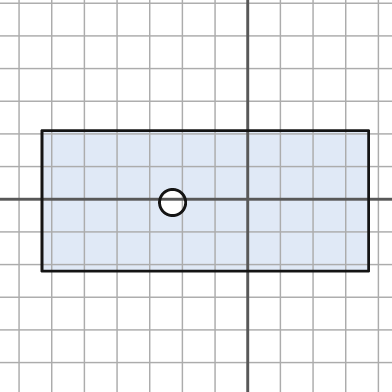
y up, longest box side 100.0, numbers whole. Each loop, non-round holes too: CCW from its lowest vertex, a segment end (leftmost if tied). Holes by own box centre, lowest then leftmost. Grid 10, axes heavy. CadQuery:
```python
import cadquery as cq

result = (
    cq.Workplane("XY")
    .moveTo(-63.0, -22.0)
    .lineTo(37.0, -22.0)
    .lineTo(37.0, 21.0)
    .lineTo(-63.0, 21.0)
    .close()
    .moveTo(-23.0, -1.0)
    .circle(4.0)
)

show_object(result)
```